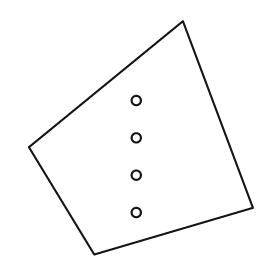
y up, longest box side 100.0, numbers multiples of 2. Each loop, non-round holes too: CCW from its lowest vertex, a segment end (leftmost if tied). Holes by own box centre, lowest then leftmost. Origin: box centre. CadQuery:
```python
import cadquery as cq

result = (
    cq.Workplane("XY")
    .moveTo(-20.0, -50.0)
    .lineTo(48.0, -30.0)
    .lineTo(18.0, 50.0)
    .lineTo(-48.0, -4.0)
    .close()
    .moveTo(-2.0, -32.0)
    .circle(2.0)
    .moveTo(-2.0, -16.0)
    .circle(2.0)
    .moveTo(-2.0, 0.0)
    .circle(2.0)
    .moveTo(-2.0, 16.0)
    .circle(2.0)
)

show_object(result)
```